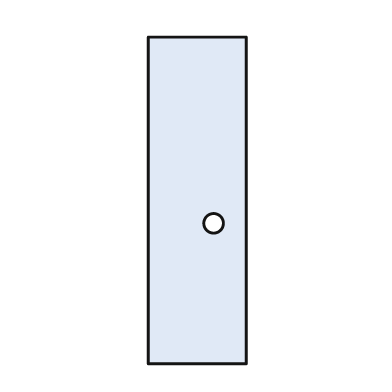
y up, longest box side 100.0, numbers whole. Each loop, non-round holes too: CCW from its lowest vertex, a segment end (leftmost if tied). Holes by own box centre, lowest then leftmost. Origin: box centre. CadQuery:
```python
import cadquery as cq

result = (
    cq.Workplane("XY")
    .moveTo(-15.0, -50.0)
    .lineTo(15.0, -50.0)
    .lineTo(15.0, 50.0)
    .lineTo(-15.0, 50.0)
    .close()
    .moveTo(5.0, -7.0)
    .circle(3.0)
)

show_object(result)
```